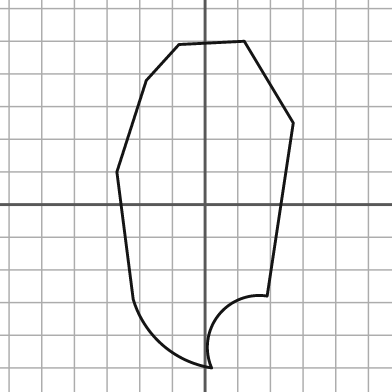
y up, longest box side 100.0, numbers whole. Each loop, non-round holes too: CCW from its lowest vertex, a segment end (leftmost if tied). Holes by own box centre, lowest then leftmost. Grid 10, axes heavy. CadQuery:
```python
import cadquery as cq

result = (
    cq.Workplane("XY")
    .moveTo(2.0, -50.0)
    .threePointArc((4.0, -34.0), (19.0, -28.0))
    .lineTo(27.0, 25.0)
    .lineTo(12.0, 50.0)
    .lineTo(-8.0, 49.0)
    .lineTo(-18.0, 38.0)
    .lineTo(-27.0, 10.0)
    .lineTo(-22.0, -29.0)
    .threePointArc((-13.0, -43.0), (2.0, -50.0))
    .close()
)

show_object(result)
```